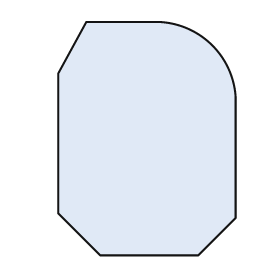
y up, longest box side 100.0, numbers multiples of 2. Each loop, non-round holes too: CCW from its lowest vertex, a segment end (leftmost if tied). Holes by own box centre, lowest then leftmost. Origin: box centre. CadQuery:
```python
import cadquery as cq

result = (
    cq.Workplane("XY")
    .moveTo(-20.0, -50.0)
    .lineTo(22.0, -50.0)
    .lineTo(38.0, -34.0)
    .lineTo(38.0, 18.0)
    .threePointArc((28.0, 40.0), (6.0, 50.0))
    .lineTo(-26.0, 50.0)
    .lineTo(-38.0, 28.0)
    .lineTo(-38.0, -32.0)
    .close()
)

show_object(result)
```